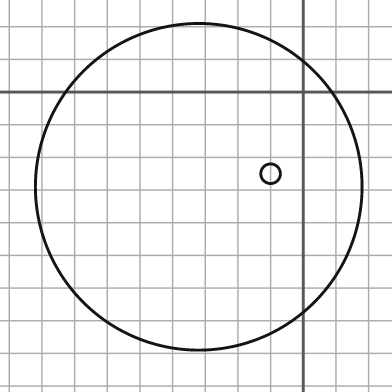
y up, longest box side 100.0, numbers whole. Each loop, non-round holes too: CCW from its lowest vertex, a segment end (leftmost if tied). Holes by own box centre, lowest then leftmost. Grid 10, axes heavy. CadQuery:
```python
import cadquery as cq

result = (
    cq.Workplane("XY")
    .moveTo(-32.0, -29.0)
    .circle(50.0)
    .moveTo(-10.0, -25.0)
    .circle(3.0)
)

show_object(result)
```